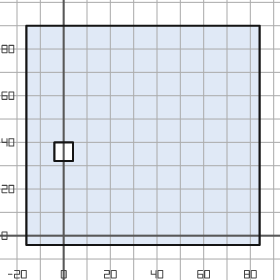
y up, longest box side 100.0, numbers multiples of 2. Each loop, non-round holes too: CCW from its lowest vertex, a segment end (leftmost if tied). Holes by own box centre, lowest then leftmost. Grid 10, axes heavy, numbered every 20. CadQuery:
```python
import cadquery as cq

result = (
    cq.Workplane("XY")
    .moveTo(-16.0, -4.0)
    .lineTo(84.0, -4.0)
    .lineTo(84.0, 90.0)
    .lineTo(-16.0, 90.0)
    .close()
    .moveTo(-4.0, 32.0)
    .lineTo(4.0, 32.0)
    .lineTo(4.0, 40.0)
    .lineTo(-4.0, 40.0)
    .close()
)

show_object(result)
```